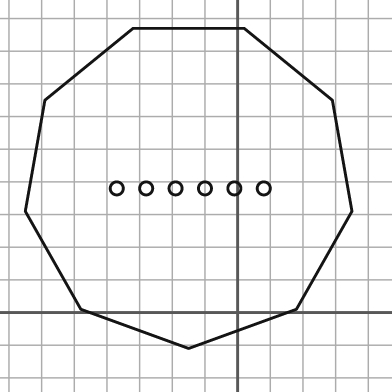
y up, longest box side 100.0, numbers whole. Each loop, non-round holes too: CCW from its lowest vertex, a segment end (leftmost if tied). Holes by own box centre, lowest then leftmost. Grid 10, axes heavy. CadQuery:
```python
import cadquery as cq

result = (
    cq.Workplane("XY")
    .moveTo(-15.0, -11.0)
    .lineTo(18.0, 1.0)
    .lineTo(35.0, 31.0)
    .lineTo(29.0, 65.0)
    .lineTo(2.0, 87.0)
    .lineTo(-32.0, 87.0)
    .lineTo(-59.0, 65.0)
    .lineTo(-65.0, 31.0)
    .lineTo(-48.0, 1.0)
    .close()
    .moveTo(-37.0, 38.0)
    .circle(2.0)
    .moveTo(-28.0, 38.0)
    .circle(2.0)
    .moveTo(-19.0, 38.0)
    .circle(2.0)
    .moveTo(-10.0, 38.0)
    .circle(2.0)
    .moveTo(-1.0, 38.0)
    .circle(2.0)
    .moveTo(8.0, 38.0)
    .circle(2.0)
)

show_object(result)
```